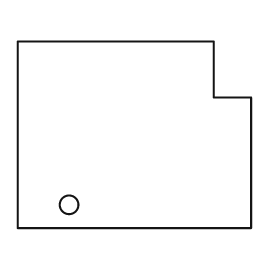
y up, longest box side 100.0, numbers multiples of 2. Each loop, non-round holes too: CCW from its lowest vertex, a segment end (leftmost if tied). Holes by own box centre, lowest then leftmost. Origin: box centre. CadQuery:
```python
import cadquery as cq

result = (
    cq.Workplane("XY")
    .moveTo(-50.0, -40.0)
    .lineTo(50.0, -40.0)
    .lineTo(50.0, 16.0)
    .lineTo(34.0, 16.0)
    .lineTo(34.0, 40.0)
    .lineTo(-50.0, 40.0)
    .close()
    .moveTo(-28.0, -30.0)
    .circle(4.0)
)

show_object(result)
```